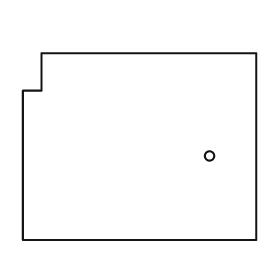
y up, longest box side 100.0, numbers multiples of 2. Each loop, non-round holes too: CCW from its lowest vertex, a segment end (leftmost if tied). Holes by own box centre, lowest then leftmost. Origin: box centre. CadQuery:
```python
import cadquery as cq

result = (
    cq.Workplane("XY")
    .moveTo(-50.0, -40.0)
    .lineTo(50.0, -40.0)
    .lineTo(50.0, 40.0)
    .lineTo(-42.0, 40.0)
    .lineTo(-42.0, 24.0)
    .lineTo(-50.0, 24.0)
    .close()
    .moveTo(30.0, -4.0)
    .circle(2.0)
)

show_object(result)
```